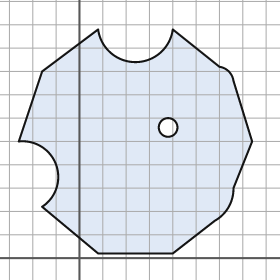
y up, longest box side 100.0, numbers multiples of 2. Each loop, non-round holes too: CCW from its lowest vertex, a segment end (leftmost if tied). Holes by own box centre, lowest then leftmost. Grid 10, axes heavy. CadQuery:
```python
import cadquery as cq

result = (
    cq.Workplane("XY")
    .moveTo(8.0, 2.0)
    .lineTo(40.0, 2.0)
    .lineTo(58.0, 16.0)
    .threePointArc((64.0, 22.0), (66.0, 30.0))
    .lineTo(74.0, 50.0)
    .lineTo(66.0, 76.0)
    .threePointArc((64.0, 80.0), (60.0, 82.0))
    .lineTo(40.0, 98.0)
    .threePointArc((24.0, 84.0), (8.0, 98.0))
    .lineTo(-16.0, 80.0)
    .lineTo(-26.0, 50.0)
    .threePointArc((-10.0, 40.0), (-16.0, 22.0))
    .close()
    .moveTo(38.0, 56.0)
    .circle(4.0)
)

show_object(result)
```